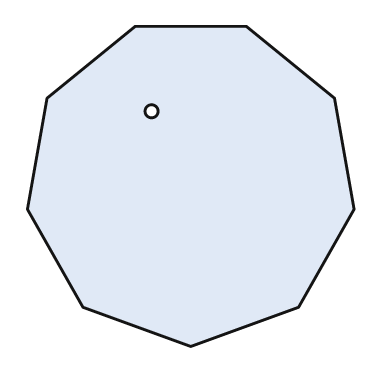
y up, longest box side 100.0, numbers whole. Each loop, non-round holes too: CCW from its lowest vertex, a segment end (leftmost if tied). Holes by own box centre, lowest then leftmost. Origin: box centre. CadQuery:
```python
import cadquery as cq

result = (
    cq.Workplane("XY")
    .moveTo(0.0, -49.0)
    .lineTo(33.0, -37.0)
    .lineTo(50.0, -7.0)
    .lineTo(44.0, 27.0)
    .lineTo(17.0, 49.0)
    .lineTo(-17.0, 49.0)
    .lineTo(-44.0, 27.0)
    .lineTo(-50.0, -7.0)
    .lineTo(-33.0, -37.0)
    .close()
    .moveTo(-12.0, 23.0)
    .circle(2.0)
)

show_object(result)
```